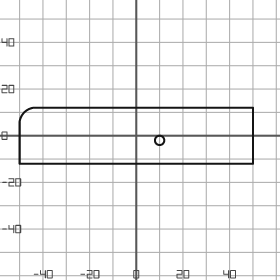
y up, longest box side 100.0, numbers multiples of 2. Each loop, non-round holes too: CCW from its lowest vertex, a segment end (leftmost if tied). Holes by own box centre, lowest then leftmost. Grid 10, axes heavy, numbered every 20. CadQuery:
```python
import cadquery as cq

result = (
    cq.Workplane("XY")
    .moveTo(-50.0, -12.0)
    .lineTo(50.0, -12.0)
    .lineTo(50.0, 12.0)
    .lineTo(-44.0, 12.0)
    .threePointArc((-48.0, 10.0), (-50.0, 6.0))
    .close()
    .moveTo(10.0, -2.0)
    .circle(2.0)
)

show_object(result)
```